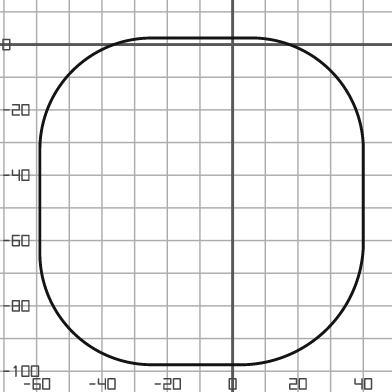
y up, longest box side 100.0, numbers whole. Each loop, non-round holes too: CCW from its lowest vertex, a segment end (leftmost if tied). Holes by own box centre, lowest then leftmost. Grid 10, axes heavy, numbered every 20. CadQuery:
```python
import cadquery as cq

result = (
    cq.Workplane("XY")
    .moveTo(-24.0, -98.0)
    .lineTo(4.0, -98.0)
    .threePointArc((29.0, -87.0), (40.0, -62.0))
    .lineTo(40.0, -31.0)
    .threePointArc((30.0, -8.0), (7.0, 2.0))
    .lineTo(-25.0, 2.0)
    .threePointArc((-49.0, -8.0), (-59.0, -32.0))
    .lineTo(-59.0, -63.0)
    .threePointArc((-49.0, -88.0), (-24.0, -98.0))
    .close()
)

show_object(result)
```